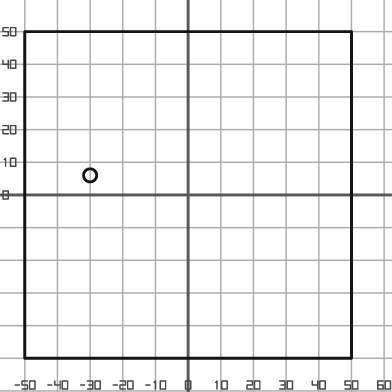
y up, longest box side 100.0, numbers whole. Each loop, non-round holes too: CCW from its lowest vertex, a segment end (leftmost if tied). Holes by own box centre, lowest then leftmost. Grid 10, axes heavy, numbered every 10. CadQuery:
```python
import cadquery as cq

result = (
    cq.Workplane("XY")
    .moveTo(-50.0, -50.0)
    .lineTo(50.0, -50.0)
    .lineTo(50.0, 50.0)
    .lineTo(-50.0, 50.0)
    .close()
    .moveTo(-30.0, 6.0)
    .circle(2.0)
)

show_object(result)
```